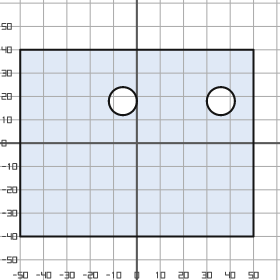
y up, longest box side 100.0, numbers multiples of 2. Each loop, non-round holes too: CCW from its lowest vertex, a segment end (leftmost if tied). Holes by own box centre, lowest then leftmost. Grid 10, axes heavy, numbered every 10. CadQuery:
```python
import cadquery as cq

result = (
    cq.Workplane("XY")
    .moveTo(-50.0, -40.0)
    .lineTo(50.0, -40.0)
    .lineTo(50.0, 40.0)
    .lineTo(-50.0, 40.0)
    .close()
    .moveTo(-6.0, 18.0)
    .circle(6.0)
    .moveTo(36.0, 18.0)
    .circle(6.0)
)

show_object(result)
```